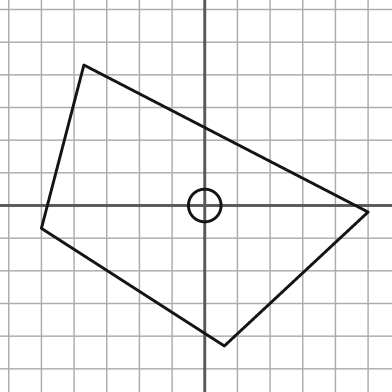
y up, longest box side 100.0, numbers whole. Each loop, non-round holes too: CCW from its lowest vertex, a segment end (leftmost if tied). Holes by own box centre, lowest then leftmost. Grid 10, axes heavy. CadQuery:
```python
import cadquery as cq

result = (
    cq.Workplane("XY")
    .moveTo(6.0, -43.0)
    .lineTo(50.0, -2.0)
    .lineTo(-37.0, 43.0)
    .lineTo(-50.0, -7.0)
    .close()
    .moveTo(0.0, 0.0)
    .circle(5.0)
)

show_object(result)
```